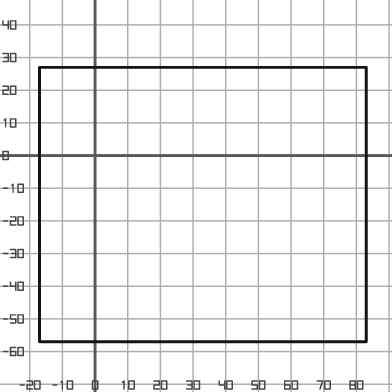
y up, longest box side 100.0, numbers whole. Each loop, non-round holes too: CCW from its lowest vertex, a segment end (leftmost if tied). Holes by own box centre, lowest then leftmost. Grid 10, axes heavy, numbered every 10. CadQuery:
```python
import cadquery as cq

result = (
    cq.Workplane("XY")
    .moveTo(-17.0, -57.0)
    .lineTo(83.0, -57.0)
    .lineTo(83.0, 27.0)
    .lineTo(-17.0, 27.0)
    .close()
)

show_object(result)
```